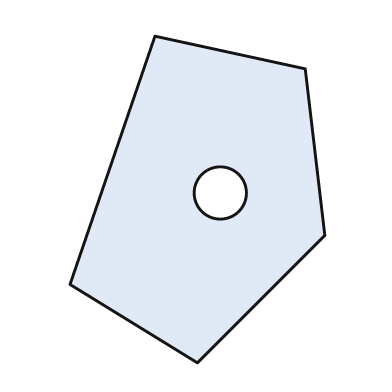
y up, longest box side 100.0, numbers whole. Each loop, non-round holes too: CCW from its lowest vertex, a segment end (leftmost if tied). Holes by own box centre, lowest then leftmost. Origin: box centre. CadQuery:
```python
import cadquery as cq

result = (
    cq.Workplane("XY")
    .moveTo(0.0, -50.0)
    .lineTo(39.0, -11.0)
    .lineTo(33.0, 40.0)
    .lineTo(-13.0, 50.0)
    .lineTo(-39.0, -26.0)
    .close()
    .moveTo(7.0, 2.0)
    .circle(8.0)
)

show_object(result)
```